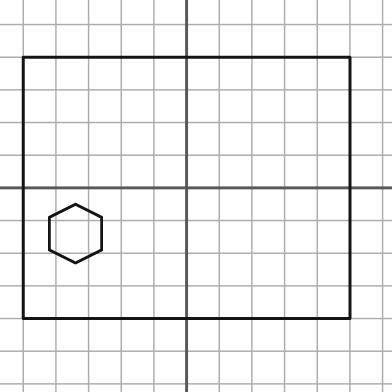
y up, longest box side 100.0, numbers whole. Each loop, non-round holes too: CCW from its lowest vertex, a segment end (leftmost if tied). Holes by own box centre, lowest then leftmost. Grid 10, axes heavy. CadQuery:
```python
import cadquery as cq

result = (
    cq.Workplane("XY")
    .moveTo(-50.0, -40.0)
    .lineTo(50.0, -40.0)
    .lineTo(50.0, 40.0)
    .lineTo(-50.0, 40.0)
    .close()
    .moveTo(-34.0, -23.0)
    .lineTo(-26.0, -19.0)
    .lineTo(-26.0, -9.0)
    .lineTo(-34.0, -5.0)
    .lineTo(-42.0, -9.0)
    .lineTo(-42.0, -19.0)
    .close()
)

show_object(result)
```